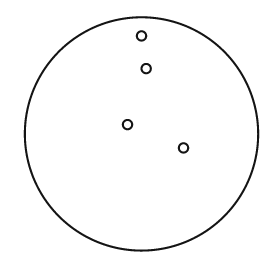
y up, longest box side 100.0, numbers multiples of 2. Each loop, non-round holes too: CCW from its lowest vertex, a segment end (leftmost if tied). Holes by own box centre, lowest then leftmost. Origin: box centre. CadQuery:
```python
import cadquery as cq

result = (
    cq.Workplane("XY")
    .moveTo(0.0, 0.0)
    .circle(50.0)
    .moveTo(18.0, -6.0)
    .circle(2.0)
    .moveTo(-6.0, 4.0)
    .circle(2.0)
    .moveTo(2.0, 28.0)
    .circle(2.0)
    .moveTo(0.0, 42.0)
    .circle(2.0)
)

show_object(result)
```